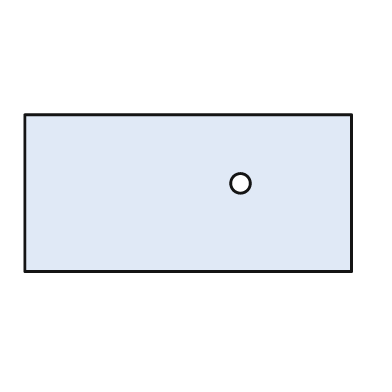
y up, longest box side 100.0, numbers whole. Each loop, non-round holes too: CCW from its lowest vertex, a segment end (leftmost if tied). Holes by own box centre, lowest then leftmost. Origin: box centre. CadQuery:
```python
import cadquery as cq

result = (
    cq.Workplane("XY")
    .moveTo(-50.0, -24.0)
    .lineTo(50.0, -24.0)
    .lineTo(50.0, 24.0)
    .lineTo(-50.0, 24.0)
    .close()
    .moveTo(16.0, 3.0)
    .circle(3.0)
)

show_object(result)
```